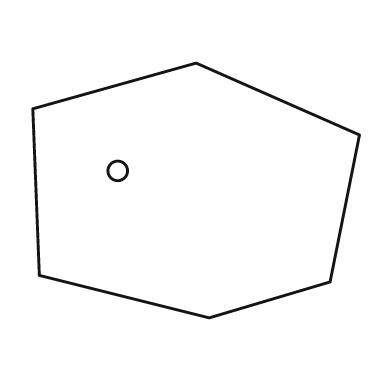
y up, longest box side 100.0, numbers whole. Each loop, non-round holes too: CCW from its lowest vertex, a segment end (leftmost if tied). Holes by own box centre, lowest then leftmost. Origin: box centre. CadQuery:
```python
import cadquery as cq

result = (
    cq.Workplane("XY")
    .moveTo(4.0, -39.0)
    .lineTo(41.0, -28.0)
    .lineTo(50.0, 17.0)
    .lineTo(0.0, 39.0)
    .lineTo(-50.0, 25.0)
    .lineTo(-48.0, -26.0)
    .close()
    .moveTo(-24.0, 6.0)
    .circle(3.0)
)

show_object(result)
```